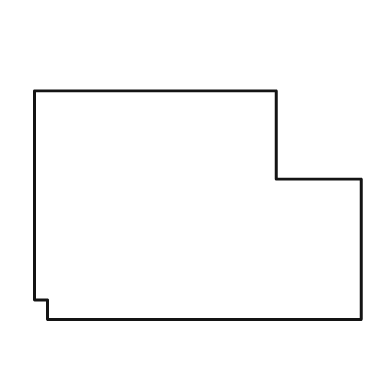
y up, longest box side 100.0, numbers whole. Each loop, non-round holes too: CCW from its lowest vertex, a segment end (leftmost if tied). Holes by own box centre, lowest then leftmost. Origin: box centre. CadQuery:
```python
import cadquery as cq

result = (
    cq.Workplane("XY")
    .moveTo(-46.0, -35.0)
    .lineTo(50.0, -35.0)
    .lineTo(50.0, 8.0)
    .lineTo(24.0, 8.0)
    .lineTo(24.0, 35.0)
    .lineTo(-50.0, 35.0)
    .lineTo(-50.0, -29.0)
    .lineTo(-46.0, -29.0)
    .close()
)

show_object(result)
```